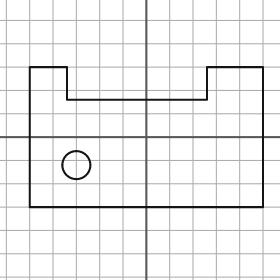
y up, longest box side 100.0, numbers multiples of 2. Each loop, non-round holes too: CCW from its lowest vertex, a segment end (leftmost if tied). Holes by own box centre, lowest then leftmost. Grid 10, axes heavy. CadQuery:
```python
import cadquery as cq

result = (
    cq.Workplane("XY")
    .moveTo(-50.0, -30.0)
    .lineTo(50.0, -30.0)
    .lineTo(50.0, 30.0)
    .lineTo(26.0, 30.0)
    .lineTo(26.0, 16.0)
    .lineTo(-34.0, 16.0)
    .lineTo(-34.0, 30.0)
    .lineTo(-50.0, 30.0)
    .close()
    .moveTo(-30.0, -12.0)
    .circle(6.0)
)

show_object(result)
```